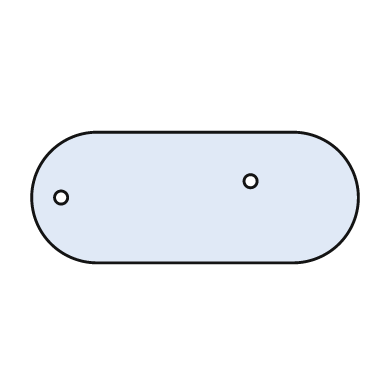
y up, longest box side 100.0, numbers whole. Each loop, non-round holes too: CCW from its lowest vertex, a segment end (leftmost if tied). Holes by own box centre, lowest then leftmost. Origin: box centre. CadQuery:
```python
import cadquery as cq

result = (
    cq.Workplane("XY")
    .moveTo(-30.0, -20.0)
    .lineTo(30.0, -20.0)
    .threePointArc((50.0, 0.0), (30.0, 20.0))
    .lineTo(-30.0, 20.0)
    .threePointArc((-50.0, 0.0), (-30.0, -20.0))
    .close()
    .moveTo(-41.0, 0.0)
    .circle(2.0)
    .moveTo(17.0, 5.0)
    .circle(2.0)
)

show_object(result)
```